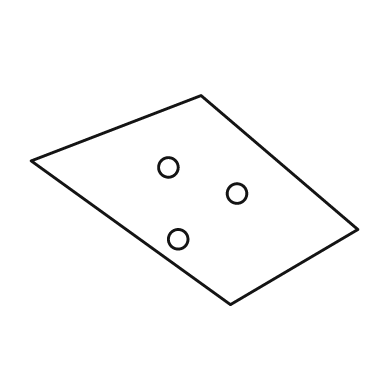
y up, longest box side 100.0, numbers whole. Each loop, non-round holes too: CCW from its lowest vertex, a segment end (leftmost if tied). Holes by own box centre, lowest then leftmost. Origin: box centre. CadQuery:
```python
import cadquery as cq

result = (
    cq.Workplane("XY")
    .moveTo(11.0, -32.0)
    .lineTo(50.0, -9.0)
    .lineTo(2.0, 32.0)
    .lineTo(-50.0, 12.0)
    .close()
    .moveTo(-5.0, -12.0)
    .circle(3.0)
    .moveTo(13.0, 2.0)
    .circle(3.0)
    .moveTo(-8.0, 10.0)
    .circle(3.0)
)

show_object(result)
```